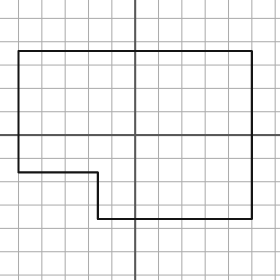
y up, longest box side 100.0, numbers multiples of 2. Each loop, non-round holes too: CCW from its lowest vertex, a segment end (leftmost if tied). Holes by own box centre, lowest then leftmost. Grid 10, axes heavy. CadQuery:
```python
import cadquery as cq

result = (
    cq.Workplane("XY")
    .moveTo(-16.0, -36.0)
    .lineTo(50.0, -36.0)
    .lineTo(50.0, 36.0)
    .lineTo(-50.0, 36.0)
    .lineTo(-50.0, -16.0)
    .lineTo(-16.0, -16.0)
    .close()
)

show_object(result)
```